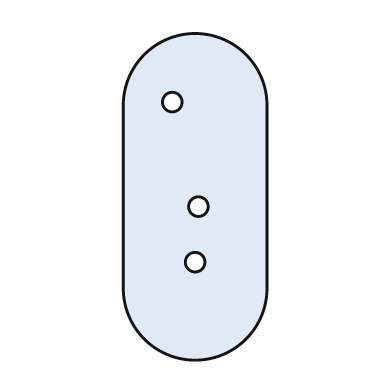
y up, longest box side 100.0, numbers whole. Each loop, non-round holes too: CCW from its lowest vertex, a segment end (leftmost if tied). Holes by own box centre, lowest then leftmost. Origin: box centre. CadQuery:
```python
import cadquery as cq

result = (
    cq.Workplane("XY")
    .moveTo(-22.0, -28.0)
    .threePointArc((0.0, -50.0), (22.0, -28.0))
    .lineTo(22.0, 28.0)
    .threePointArc((0.0, 50.0), (-22.0, 28.0))
    .close()
    .moveTo(0.0, -20.0)
    .circle(3.0)
    .moveTo(1.0, -3.0)
    .circle(3.0)
    .moveTo(-7.0, 29.0)
    .circle(3.0)
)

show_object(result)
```